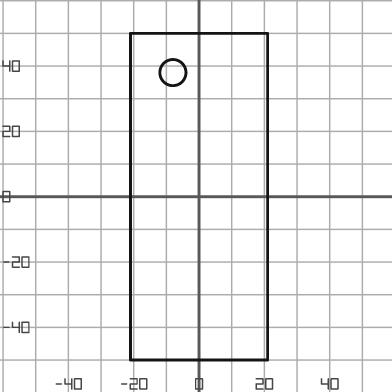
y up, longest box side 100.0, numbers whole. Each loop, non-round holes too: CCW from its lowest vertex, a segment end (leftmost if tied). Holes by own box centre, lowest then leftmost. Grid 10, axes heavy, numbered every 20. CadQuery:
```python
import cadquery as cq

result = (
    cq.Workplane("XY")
    .moveTo(-21.0, -50.0)
    .lineTo(21.0, -50.0)
    .lineTo(21.0, 50.0)
    .lineTo(-21.0, 50.0)
    .close()
    .moveTo(-8.0, 38.0)
    .circle(4.0)
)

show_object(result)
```